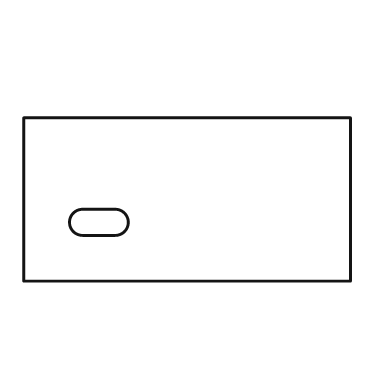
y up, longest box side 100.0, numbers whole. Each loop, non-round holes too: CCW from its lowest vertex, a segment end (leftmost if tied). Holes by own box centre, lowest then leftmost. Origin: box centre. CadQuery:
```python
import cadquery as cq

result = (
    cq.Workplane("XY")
    .moveTo(-50.0, -25.0)
    .lineTo(50.0, -25.0)
    .lineTo(50.0, 25.0)
    .lineTo(-50.0, 25.0)
    .close()
    .moveTo(-32.0, -11.0)
    .lineTo(-22.0, -11.0)
    .threePointArc((-18.0, -7.0), (-22.0, -3.0))
    .lineTo(-32.0, -3.0)
    .threePointArc((-36.0, -7.0), (-32.0, -11.0))
    .close()
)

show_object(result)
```